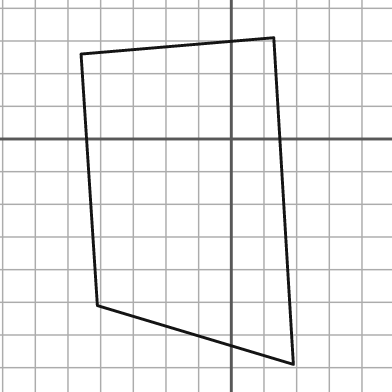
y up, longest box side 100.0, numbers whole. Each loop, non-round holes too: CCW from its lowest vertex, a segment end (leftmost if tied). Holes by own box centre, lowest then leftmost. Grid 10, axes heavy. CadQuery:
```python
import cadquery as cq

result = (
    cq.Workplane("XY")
    .moveTo(19.0, -69.0)
    .lineTo(13.0, 31.0)
    .lineTo(-46.0, 26.0)
    .lineTo(-41.0, -51.0)
    .close()
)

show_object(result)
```